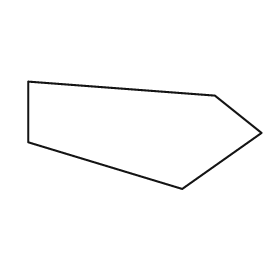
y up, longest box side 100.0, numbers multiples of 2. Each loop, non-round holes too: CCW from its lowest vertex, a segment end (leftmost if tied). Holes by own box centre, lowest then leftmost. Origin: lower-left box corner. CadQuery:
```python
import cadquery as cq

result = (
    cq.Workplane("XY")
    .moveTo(66.0, 0.0)
    .lineTo(100.0, 24.0)
    .lineTo(80.0, 40.0)
    .lineTo(0.0, 46.0)
    .lineTo(0.0, 20.0)
    .close()
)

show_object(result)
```